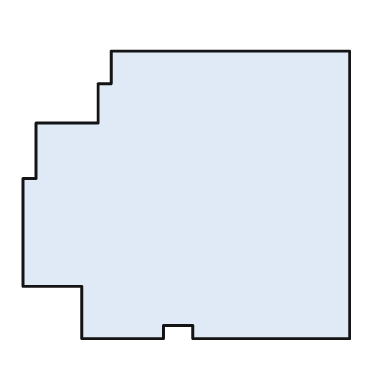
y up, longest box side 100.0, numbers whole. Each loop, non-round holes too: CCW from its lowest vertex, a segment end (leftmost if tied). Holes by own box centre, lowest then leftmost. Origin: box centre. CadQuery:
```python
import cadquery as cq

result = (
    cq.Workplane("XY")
    .moveTo(-32.0, -44.0)
    .lineTo(-7.0, -44.0)
    .lineTo(-7.0, -40.0)
    .lineTo(2.0, -40.0)
    .lineTo(2.0, -44.0)
    .lineTo(50.0, -44.0)
    .lineTo(50.0, 44.0)
    .lineTo(-23.0, 44.0)
    .lineTo(-23.0, 34.0)
    .lineTo(-27.0, 34.0)
    .lineTo(-27.0, 22.0)
    .lineTo(-46.0, 22.0)
    .lineTo(-46.0, 5.0)
    .lineTo(-50.0, 5.0)
    .lineTo(-50.0, -28.0)
    .lineTo(-32.0, -28.0)
    .close()
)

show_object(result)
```